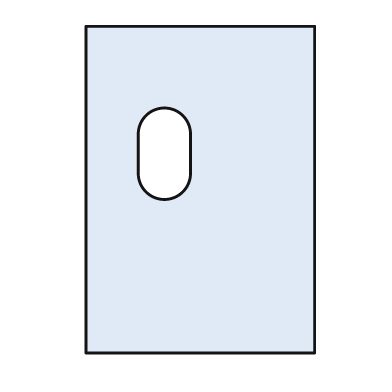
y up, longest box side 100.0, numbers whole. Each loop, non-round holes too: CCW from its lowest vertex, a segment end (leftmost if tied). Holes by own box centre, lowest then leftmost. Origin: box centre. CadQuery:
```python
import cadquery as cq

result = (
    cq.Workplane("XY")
    .moveTo(-35.0, -50.0)
    .lineTo(35.0, -50.0)
    .lineTo(35.0, 50.0)
    .lineTo(-35.0, 50.0)
    .close()
    .moveTo(-19.0, 5.0)
    .threePointArc((-11.0, -3.0), (-3.0, 5.0))
    .lineTo(-3.0, 17.0)
    .threePointArc((-11.0, 25.0), (-19.0, 17.0))
    .close()
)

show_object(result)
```